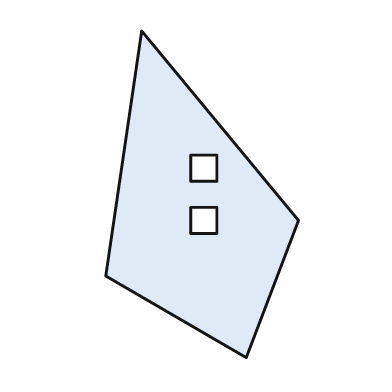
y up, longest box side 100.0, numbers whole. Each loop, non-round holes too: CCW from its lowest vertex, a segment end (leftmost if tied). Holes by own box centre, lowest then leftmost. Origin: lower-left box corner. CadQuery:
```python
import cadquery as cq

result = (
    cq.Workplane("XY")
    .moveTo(43.0, 0.0)
    .lineTo(59.0, 42.0)
    .lineTo(11.0, 100.0)
    .lineTo(0.0, 25.0)
    .close()
    .moveTo(26.0, 38.0)
    .lineTo(34.0, 38.0)
    .lineTo(34.0, 46.0)
    .lineTo(26.0, 46.0)
    .close()
    .moveTo(26.0, 54.0)
    .lineTo(34.0, 54.0)
    .lineTo(34.0, 62.0)
    .lineTo(26.0, 62.0)
    .close()
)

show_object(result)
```